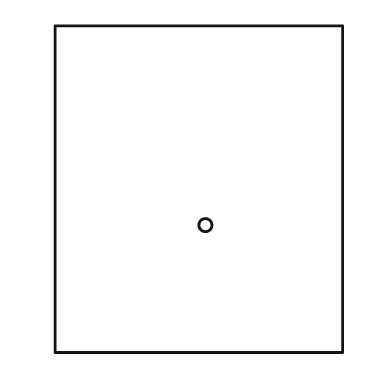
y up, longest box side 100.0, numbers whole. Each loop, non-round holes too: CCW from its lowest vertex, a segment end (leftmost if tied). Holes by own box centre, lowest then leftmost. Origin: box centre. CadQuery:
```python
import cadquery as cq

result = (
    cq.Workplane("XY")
    .moveTo(-44.0, -50.0)
    .lineTo(44.0, -50.0)
    .lineTo(44.0, 50.0)
    .lineTo(-44.0, 50.0)
    .close()
    .moveTo(2.0, -11.0)
    .circle(2.0)
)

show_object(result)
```